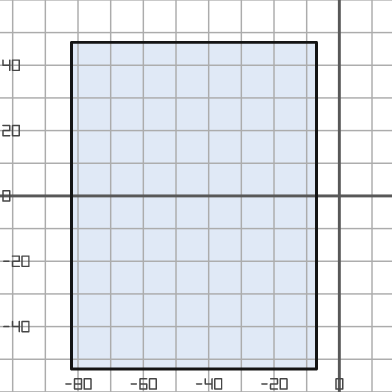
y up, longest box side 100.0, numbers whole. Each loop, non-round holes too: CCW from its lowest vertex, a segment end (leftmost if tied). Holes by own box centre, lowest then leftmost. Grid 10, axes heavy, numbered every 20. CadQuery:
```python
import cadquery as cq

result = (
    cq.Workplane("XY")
    .moveTo(-82.0, -53.0)
    .lineTo(-7.0, -53.0)
    .lineTo(-7.0, 47.0)
    .lineTo(-82.0, 47.0)
    .close()
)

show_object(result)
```